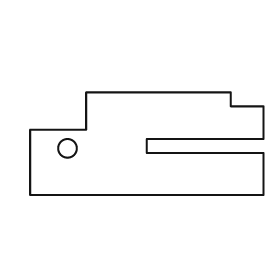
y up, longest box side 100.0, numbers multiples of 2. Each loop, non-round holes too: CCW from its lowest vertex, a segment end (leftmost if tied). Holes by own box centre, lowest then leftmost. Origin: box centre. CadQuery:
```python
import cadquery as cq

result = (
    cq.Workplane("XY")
    .moveTo(-50.0, -22.0)
    .lineTo(50.0, -22.0)
    .lineTo(50.0, -4.0)
    .lineTo(0.0, -4.0)
    .lineTo(0.0, 2.0)
    .lineTo(50.0, 2.0)
    .lineTo(50.0, 16.0)
    .lineTo(36.0, 16.0)
    .lineTo(36.0, 22.0)
    .lineTo(-26.0, 22.0)
    .lineTo(-26.0, 6.0)
    .lineTo(-50.0, 6.0)
    .close()
    .moveTo(-34.0, -2.0)
    .circle(4.0)
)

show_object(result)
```